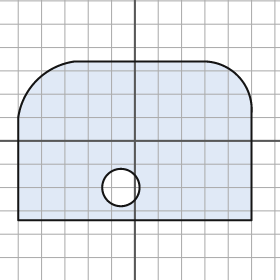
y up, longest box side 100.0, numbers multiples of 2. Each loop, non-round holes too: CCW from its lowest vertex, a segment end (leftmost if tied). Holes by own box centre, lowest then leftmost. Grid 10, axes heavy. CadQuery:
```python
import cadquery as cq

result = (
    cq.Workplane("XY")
    .moveTo(-50.0, -34.0)
    .lineTo(50.0, -34.0)
    .lineTo(50.0, 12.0)
    .threePointArc((44.0, 28.0), (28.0, 34.0))
    .lineTo(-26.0, 34.0)
    .threePointArc((-42.0, 26.0), (-50.0, 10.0))
    .close()
    .moveTo(-6.0, -20.0)
    .circle(8.0)
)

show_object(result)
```